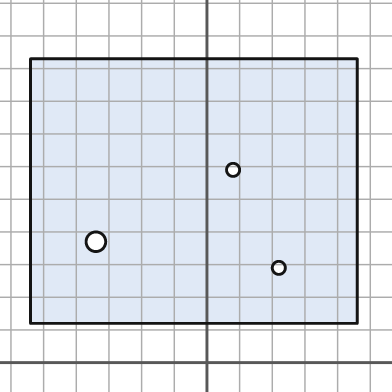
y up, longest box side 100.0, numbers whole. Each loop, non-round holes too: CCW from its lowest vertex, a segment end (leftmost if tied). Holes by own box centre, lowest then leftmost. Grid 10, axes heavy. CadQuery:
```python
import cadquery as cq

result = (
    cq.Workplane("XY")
    .moveTo(-54.0, 12.0)
    .lineTo(46.0, 12.0)
    .lineTo(46.0, 93.0)
    .lineTo(-54.0, 93.0)
    .close()
    .moveTo(22.0, 29.0)
    .circle(2.0)
    .moveTo(-34.0, 37.0)
    .circle(3.0)
    .moveTo(8.0, 59.0)
    .circle(2.0)
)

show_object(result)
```